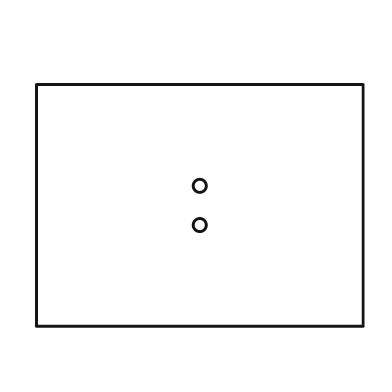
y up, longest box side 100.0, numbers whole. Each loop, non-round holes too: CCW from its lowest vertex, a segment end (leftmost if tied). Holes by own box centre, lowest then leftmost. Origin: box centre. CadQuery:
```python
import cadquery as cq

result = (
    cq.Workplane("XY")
    .moveTo(-50.0, -37.0)
    .lineTo(50.0, -37.0)
    .lineTo(50.0, 37.0)
    .lineTo(-50.0, 37.0)
    .close()
    .moveTo(0.0, -6.0)
    .circle(2.0)
    .moveTo(0.0, 6.0)
    .circle(2.0)
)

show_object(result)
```